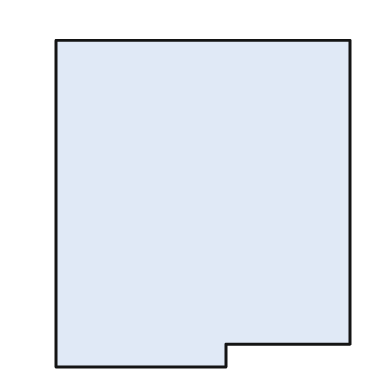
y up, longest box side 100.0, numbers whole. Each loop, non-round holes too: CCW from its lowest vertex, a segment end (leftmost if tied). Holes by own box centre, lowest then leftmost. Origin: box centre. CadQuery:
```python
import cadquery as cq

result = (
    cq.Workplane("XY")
    .moveTo(-45.0, -50.0)
    .lineTo(7.0, -50.0)
    .lineTo(7.0, -43.0)
    .lineTo(45.0, -43.0)
    .lineTo(45.0, 50.0)
    .lineTo(-45.0, 50.0)
    .close()
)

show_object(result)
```